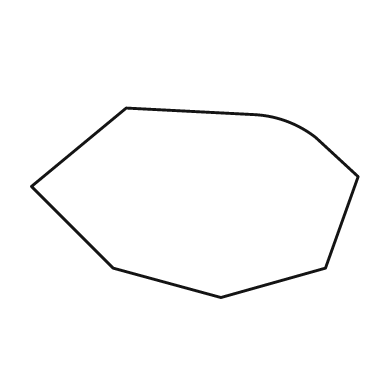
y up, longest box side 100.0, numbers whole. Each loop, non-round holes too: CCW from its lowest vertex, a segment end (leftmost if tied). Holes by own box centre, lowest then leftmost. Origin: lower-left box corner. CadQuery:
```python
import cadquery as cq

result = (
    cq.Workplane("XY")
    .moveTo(58.0, 0.0)
    .lineTo(90.0, 9.0)
    .lineTo(100.0, 37.0)
    .lineTo(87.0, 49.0)
    .threePointArc((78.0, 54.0), (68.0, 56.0))
    .lineTo(29.0, 58.0)
    .lineTo(0.0, 34.0)
    .lineTo(25.0, 9.0)
    .close()
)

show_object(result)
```